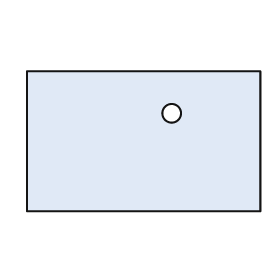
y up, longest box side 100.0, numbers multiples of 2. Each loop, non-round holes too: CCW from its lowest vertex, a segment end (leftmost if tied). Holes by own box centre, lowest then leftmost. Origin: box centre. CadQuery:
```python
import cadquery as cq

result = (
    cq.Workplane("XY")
    .moveTo(-50.0, -30.0)
    .lineTo(50.0, -30.0)
    .lineTo(50.0, 30.0)
    .lineTo(-50.0, 30.0)
    .close()
    .moveTo(12.0, 12.0)
    .circle(4.0)
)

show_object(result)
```